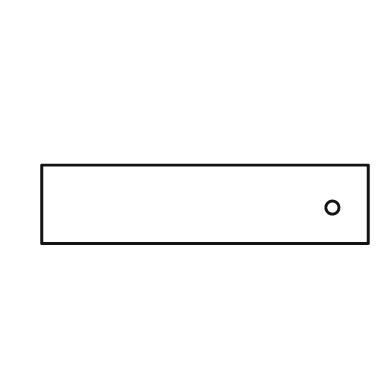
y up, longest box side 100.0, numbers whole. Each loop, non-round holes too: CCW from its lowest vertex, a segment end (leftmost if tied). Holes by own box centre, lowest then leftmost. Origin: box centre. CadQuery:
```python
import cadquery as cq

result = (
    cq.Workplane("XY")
    .moveTo(-50.0, -12.0)
    .lineTo(50.0, -12.0)
    .lineTo(50.0, 12.0)
    .lineTo(-50.0, 12.0)
    .close()
    .moveTo(39.0, -1.0)
    .circle(2.0)
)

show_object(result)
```